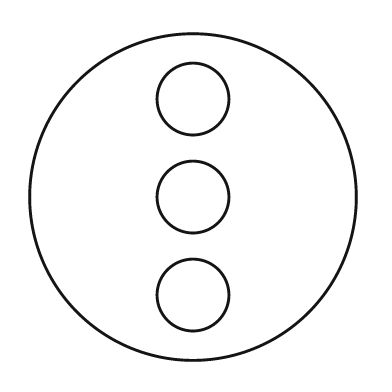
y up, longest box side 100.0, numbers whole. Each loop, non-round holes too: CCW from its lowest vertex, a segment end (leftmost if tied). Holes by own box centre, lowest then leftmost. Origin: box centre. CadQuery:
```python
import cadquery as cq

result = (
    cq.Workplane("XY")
    .moveTo(0.0, 0.0)
    .circle(50.0)
    .moveTo(0.0, -30.0)
    .circle(11.0)
    .moveTo(0.0, 0.0)
    .circle(11.0)
    .moveTo(0.0, 30.0)
    .circle(11.0)
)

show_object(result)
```